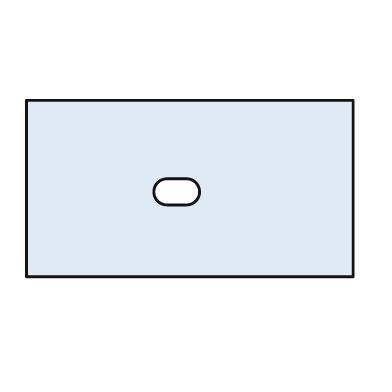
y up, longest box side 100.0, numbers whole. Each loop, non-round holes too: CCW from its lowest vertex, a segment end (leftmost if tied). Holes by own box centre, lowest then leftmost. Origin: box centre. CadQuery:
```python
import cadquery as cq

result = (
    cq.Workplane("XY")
    .moveTo(-50.0, -27.0)
    .lineTo(50.0, -27.0)
    .lineTo(50.0, 27.0)
    .lineTo(-50.0, 27.0)
    .close()
    .moveTo(-7.0, -5.0)
    .lineTo(-1.0, -5.0)
    .threePointArc((3.0, -1.0), (-1.0, 3.0))
    .lineTo(-7.0, 3.0)
    .threePointArc((-11.0, -1.0), (-7.0, -5.0))
    .close()
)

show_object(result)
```